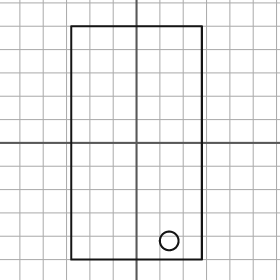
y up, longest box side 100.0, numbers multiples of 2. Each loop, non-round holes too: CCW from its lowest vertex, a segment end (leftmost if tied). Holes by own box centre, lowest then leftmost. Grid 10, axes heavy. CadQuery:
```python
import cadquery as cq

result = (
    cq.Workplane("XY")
    .moveTo(-28.0, -50.0)
    .lineTo(28.0, -50.0)
    .lineTo(28.0, 50.0)
    .lineTo(-28.0, 50.0)
    .close()
    .moveTo(14.0, -42.0)
    .circle(4.0)
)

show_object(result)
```